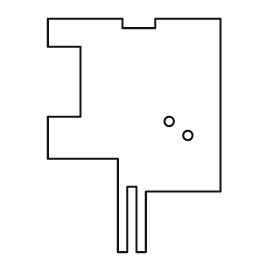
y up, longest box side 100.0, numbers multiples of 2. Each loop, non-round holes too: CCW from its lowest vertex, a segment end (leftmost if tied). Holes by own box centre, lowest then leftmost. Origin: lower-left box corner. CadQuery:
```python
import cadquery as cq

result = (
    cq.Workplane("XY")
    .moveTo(30.0, 0.0)
    .lineTo(34.0, 0.0)
    .lineTo(34.0, 28.0)
    .lineTo(38.0, 28.0)
    .lineTo(38.0, 0.0)
    .lineTo(42.0, 0.0)
    .lineTo(42.0, 26.0)
    .lineTo(74.0, 26.0)
    .lineTo(74.0, 100.0)
    .lineTo(46.0, 100.0)
    .lineTo(46.0, 96.0)
    .lineTo(32.0, 96.0)
    .lineTo(32.0, 100.0)
    .lineTo(0.0, 100.0)
    .lineTo(0.0, 88.0)
    .lineTo(14.0, 88.0)
    .lineTo(14.0, 58.0)
    .lineTo(0.0, 58.0)
    .lineTo(0.0, 40.0)
    .lineTo(30.0, 40.0)
    .close()
    .moveTo(60.0, 50.0)
    .circle(2.0)
    .moveTo(52.0, 56.0)
    .circle(2.0)
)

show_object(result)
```